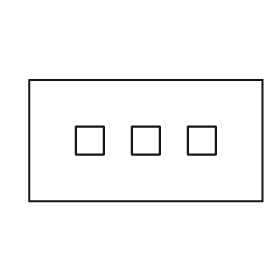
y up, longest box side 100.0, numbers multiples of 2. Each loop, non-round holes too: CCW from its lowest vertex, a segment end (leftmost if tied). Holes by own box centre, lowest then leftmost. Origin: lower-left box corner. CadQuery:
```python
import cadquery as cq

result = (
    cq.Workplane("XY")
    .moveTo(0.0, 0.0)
    .lineTo(100.0, 0.0)
    .lineTo(100.0, 52.0)
    .lineTo(0.0, 52.0)
    .close()
    .moveTo(20.0, 20.0)
    .lineTo(32.0, 20.0)
    .lineTo(32.0, 32.0)
    .lineTo(20.0, 32.0)
    .close()
    .moveTo(44.0, 20.0)
    .lineTo(56.0, 20.0)
    .lineTo(56.0, 32.0)
    .lineTo(44.0, 32.0)
    .close()
    .moveTo(68.0, 20.0)
    .lineTo(80.0, 20.0)
    .lineTo(80.0, 32.0)
    .lineTo(68.0, 32.0)
    .close()
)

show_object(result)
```